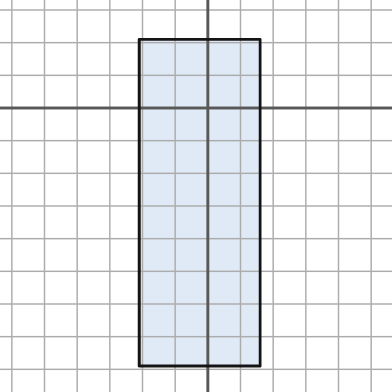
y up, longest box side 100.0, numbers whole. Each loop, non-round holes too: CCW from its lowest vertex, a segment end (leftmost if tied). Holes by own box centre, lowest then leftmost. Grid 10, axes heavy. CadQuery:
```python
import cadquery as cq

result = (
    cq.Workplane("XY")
    .moveTo(-21.0, -79.0)
    .lineTo(16.0, -79.0)
    .lineTo(16.0, 21.0)
    .lineTo(-21.0, 21.0)
    .close()
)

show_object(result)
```